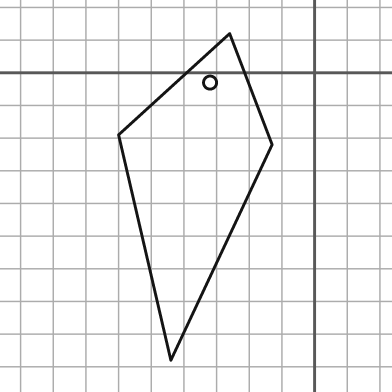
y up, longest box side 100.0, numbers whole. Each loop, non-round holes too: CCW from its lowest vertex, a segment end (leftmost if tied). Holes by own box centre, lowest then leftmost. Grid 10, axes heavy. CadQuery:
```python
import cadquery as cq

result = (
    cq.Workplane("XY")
    .moveTo(-44.0, -88.0)
    .lineTo(-13.0, -22.0)
    .lineTo(-26.0, 12.0)
    .lineTo(-60.0, -19.0)
    .close()
    .moveTo(-32.0, -3.0)
    .circle(2.0)
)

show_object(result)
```